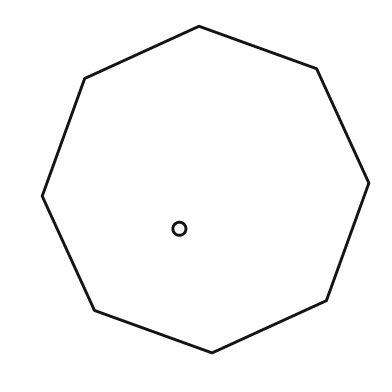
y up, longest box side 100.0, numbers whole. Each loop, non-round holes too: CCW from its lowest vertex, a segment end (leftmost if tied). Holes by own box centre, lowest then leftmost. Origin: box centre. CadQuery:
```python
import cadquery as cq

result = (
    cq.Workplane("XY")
    .moveTo(2.0, -50.0)
    .lineTo(37.0, -34.0)
    .lineTo(50.0, 2.0)
    .lineTo(34.0, 37.0)
    .lineTo(-2.0, 50.0)
    .lineTo(-37.0, 34.0)
    .lineTo(-50.0, -2.0)
    .lineTo(-34.0, -37.0)
    .close()
    .moveTo(-8.0, -12.0)
    .circle(2.0)
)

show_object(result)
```